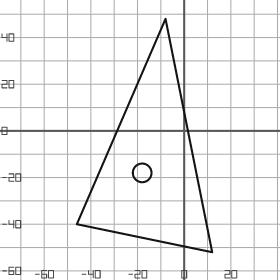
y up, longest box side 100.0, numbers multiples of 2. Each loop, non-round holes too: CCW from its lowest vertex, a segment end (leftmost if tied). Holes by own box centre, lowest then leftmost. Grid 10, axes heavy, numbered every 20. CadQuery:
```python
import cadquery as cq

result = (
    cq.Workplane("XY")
    .moveTo(12.0, -52.0)
    .lineTo(-8.0, 48.0)
    .lineTo(-46.0, -40.0)
    .close()
    .moveTo(-18.0, -18.0)
    .circle(4.0)
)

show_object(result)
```